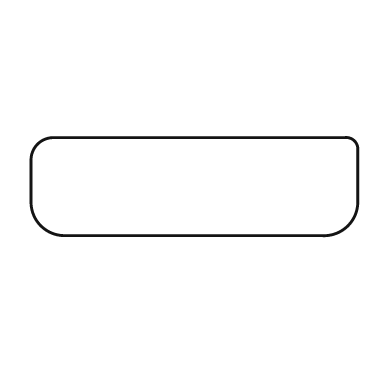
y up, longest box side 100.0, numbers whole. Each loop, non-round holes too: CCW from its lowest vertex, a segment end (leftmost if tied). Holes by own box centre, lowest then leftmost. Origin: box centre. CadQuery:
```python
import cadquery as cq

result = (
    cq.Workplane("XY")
    .moveTo(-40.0, -15.0)
    .lineTo(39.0, -15.0)
    .threePointArc((47.0, -12.0), (50.0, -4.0))
    .lineTo(50.0, 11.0)
    .threePointArc((49.0, 14.0), (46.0, 15.0))
    .lineTo(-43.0, 15.0)
    .threePointArc((-48.0, 13.0), (-50.0, 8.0))
    .lineTo(-50.0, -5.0)
    .threePointArc((-47.0, -12.0), (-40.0, -15.0))
    .close()
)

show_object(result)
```